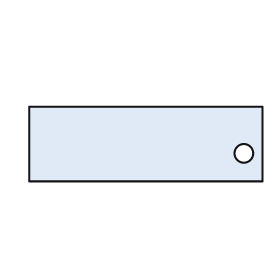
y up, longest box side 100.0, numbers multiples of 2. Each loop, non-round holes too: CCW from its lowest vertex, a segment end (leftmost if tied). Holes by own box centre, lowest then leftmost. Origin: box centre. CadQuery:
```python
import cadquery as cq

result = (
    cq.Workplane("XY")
    .moveTo(-50.0, -16.0)
    .lineTo(50.0, -16.0)
    .lineTo(50.0, 16.0)
    .lineTo(-50.0, 16.0)
    .close()
    .moveTo(42.0, -4.0)
    .circle(4.0)
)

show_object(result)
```